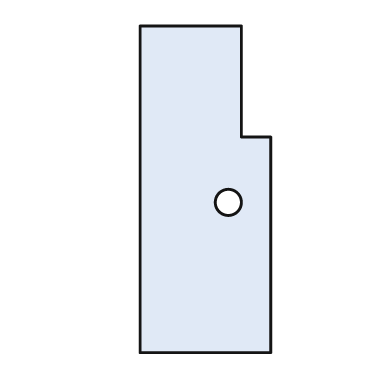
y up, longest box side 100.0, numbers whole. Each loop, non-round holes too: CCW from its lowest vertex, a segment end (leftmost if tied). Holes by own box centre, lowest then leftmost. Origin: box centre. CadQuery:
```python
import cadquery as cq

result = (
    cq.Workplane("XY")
    .moveTo(-20.0, -50.0)
    .lineTo(20.0, -50.0)
    .lineTo(20.0, 16.0)
    .lineTo(11.0, 16.0)
    .lineTo(11.0, 50.0)
    .lineTo(-20.0, 50.0)
    .close()
    .moveTo(7.0, -4.0)
    .circle(4.0)
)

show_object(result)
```